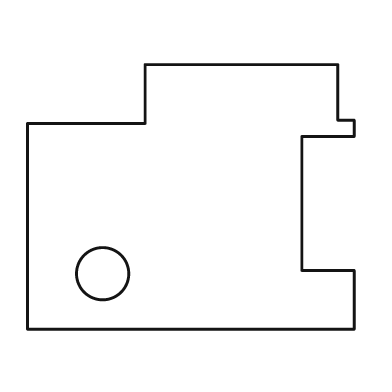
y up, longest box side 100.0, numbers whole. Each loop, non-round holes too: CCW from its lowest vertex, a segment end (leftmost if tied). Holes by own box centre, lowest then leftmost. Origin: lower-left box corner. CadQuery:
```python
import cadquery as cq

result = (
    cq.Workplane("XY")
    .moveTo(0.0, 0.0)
    .lineTo(100.0, 0.0)
    .lineTo(100.0, 18.0)
    .lineTo(84.0, 18.0)
    .lineTo(84.0, 59.0)
    .lineTo(100.0, 59.0)
    .lineTo(100.0, 64.0)
    .lineTo(95.0, 64.0)
    .lineTo(95.0, 81.0)
    .lineTo(36.0, 81.0)
    .lineTo(36.0, 63.0)
    .lineTo(0.0, 63.0)
    .close()
    .moveTo(23.0, 17.0)
    .circle(8.0)
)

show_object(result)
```